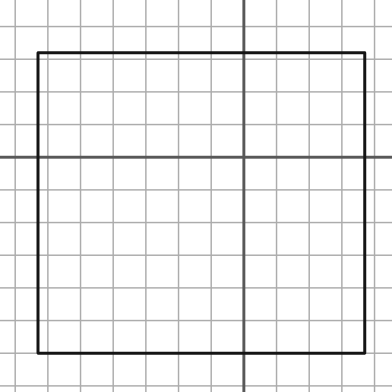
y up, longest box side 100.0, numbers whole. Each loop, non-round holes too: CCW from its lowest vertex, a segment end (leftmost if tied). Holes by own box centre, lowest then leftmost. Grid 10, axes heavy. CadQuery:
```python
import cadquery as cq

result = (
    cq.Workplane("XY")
    .moveTo(-63.0, -60.0)
    .lineTo(37.0, -60.0)
    .lineTo(37.0, 32.0)
    .lineTo(-63.0, 32.0)
    .close()
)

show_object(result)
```